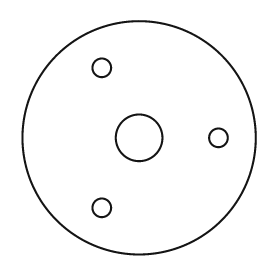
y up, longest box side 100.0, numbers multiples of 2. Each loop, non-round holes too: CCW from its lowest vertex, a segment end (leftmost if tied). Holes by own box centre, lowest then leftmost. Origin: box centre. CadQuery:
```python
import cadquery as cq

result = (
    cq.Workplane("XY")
    .moveTo(0.0, 0.0)
    .circle(50.0)
    .moveTo(-16.0, -30.0)
    .circle(4.0)
    .moveTo(0.0, 0.0)
    .circle(10.0)
    .moveTo(34.0, 0.0)
    .circle(4.0)
    .moveTo(-16.0, 30.0)
    .circle(4.0)
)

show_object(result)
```